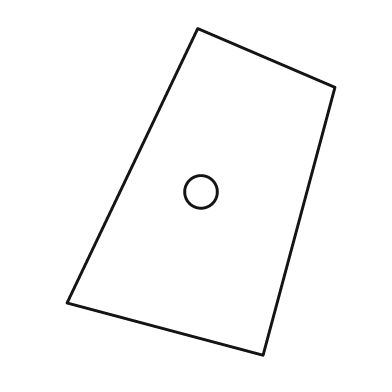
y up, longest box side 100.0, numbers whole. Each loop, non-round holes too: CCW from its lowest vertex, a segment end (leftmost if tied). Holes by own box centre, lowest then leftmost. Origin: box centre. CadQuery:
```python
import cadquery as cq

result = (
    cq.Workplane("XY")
    .moveTo(19.0, -50.0)
    .lineTo(41.0, 32.0)
    .lineTo(-1.0, 50.0)
    .lineTo(-41.0, -34.0)
    .close()
    .moveTo(0.0, 0.0)
    .circle(5.0)
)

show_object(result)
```